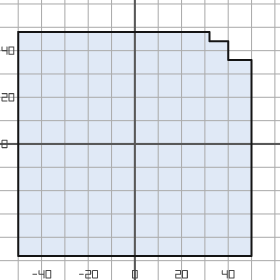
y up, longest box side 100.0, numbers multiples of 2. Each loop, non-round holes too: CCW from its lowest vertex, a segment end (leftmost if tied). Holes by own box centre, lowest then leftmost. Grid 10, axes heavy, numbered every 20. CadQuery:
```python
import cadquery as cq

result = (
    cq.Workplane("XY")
    .moveTo(-50.0, -48.0)
    .lineTo(50.0, -48.0)
    .lineTo(50.0, 36.0)
    .lineTo(40.0, 36.0)
    .lineTo(40.0, 44.0)
    .lineTo(32.0, 44.0)
    .lineTo(32.0, 48.0)
    .lineTo(-50.0, 48.0)
    .close()
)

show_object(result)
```